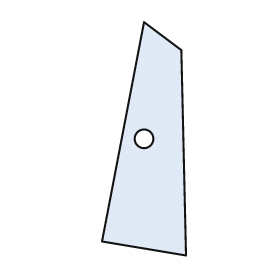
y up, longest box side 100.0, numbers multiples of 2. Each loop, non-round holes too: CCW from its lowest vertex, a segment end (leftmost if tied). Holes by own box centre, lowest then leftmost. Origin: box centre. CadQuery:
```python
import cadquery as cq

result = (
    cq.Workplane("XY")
    .moveTo(18.0, -50.0)
    .lineTo(16.0, 38.0)
    .lineTo(0.0, 50.0)
    .lineTo(-18.0, -44.0)
    .close()
    .moveTo(0.0, 0.0)
    .circle(4.0)
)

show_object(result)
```